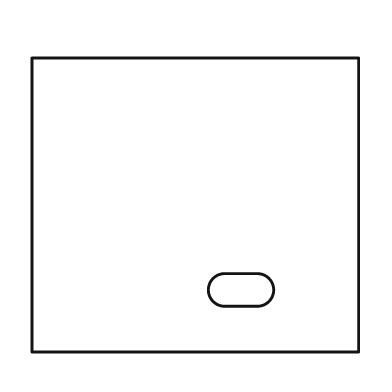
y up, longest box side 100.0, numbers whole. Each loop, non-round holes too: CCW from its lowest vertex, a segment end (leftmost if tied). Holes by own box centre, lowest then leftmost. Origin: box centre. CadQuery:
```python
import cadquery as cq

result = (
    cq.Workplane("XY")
    .moveTo(-50.0, -45.0)
    .lineTo(50.0, -45.0)
    .lineTo(50.0, 45.0)
    .lineTo(-50.0, 45.0)
    .close()
    .moveTo(9.0, -31.0)
    .lineTo(19.0, -31.0)
    .threePointArc((24.0, -26.0), (19.0, -21.0))
    .lineTo(9.0, -21.0)
    .threePointArc((4.0, -26.0), (9.0, -31.0))
    .close()
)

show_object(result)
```